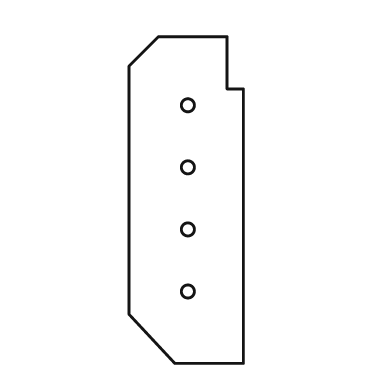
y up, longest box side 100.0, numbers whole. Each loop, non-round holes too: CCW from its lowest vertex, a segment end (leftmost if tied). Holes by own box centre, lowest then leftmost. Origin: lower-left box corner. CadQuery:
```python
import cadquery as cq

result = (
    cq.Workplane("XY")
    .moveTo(14.0, 0.0)
    .lineTo(35.0, 0.0)
    .lineTo(35.0, 84.0)
    .lineTo(30.0, 84.0)
    .lineTo(30.0, 100.0)
    .lineTo(9.0, 100.0)
    .lineTo(0.0, 91.0)
    .lineTo(0.0, 15.0)
    .close()
    .moveTo(18.0, 22.0)
    .circle(2.0)
    .moveTo(18.0, 41.0)
    .circle(2.0)
    .moveTo(18.0, 60.0)
    .circle(2.0)
    .moveTo(18.0, 79.0)
    .circle(2.0)
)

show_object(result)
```